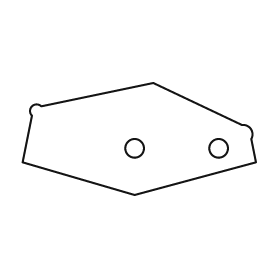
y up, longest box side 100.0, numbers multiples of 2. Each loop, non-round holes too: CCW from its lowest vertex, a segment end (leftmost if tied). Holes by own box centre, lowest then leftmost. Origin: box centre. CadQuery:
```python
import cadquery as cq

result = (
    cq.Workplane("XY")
    .moveTo(-2.0, -24.0)
    .lineTo(50.0, -10.0)
    .lineTo(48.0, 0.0)
    .threePointArc((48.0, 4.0), (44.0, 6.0))
    .lineTo(6.0, 24.0)
    .lineTo(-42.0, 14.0)
    .threePointArc((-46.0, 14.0), (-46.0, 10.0))
    .lineTo(-50.0, -10.0)
    .close()
    .moveTo(-2.0, -4.0)
    .circle(4.0)
    .moveTo(34.0, -4.0)
    .circle(4.0)
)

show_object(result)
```